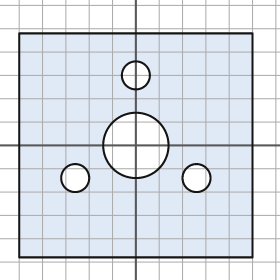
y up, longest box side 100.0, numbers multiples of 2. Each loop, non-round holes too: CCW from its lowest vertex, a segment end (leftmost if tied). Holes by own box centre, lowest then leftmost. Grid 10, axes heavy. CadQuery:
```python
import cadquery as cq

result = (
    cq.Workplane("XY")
    .moveTo(-50.0, -48.0)
    .lineTo(50.0, -48.0)
    .lineTo(50.0, 48.0)
    .lineTo(-50.0, 48.0)
    .close()
    .moveTo(-26.0, -14.0)
    .circle(6.0)
    .moveTo(26.0, -14.0)
    .circle(6.0)
    .moveTo(0.0, 0.0)
    .circle(14.0)
    .moveTo(0.0, 30.0)
    .circle(6.0)
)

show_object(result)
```